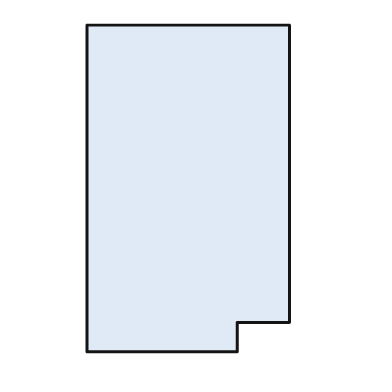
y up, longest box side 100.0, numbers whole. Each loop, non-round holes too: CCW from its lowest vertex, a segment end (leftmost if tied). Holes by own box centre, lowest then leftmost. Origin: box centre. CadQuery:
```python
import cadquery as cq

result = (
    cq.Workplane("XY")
    .moveTo(-31.0, -50.0)
    .lineTo(15.0, -50.0)
    .lineTo(15.0, -41.0)
    .lineTo(31.0, -41.0)
    .lineTo(31.0, 50.0)
    .lineTo(-31.0, 50.0)
    .close()
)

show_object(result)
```